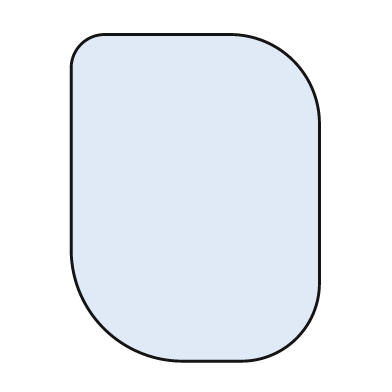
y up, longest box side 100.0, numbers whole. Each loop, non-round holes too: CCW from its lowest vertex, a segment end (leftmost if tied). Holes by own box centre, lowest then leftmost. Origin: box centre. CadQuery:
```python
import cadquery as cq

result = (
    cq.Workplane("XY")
    .moveTo(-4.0, -50.0)
    .lineTo(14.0, -50.0)
    .threePointArc((31.0, -43.0), (38.0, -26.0))
    .lineTo(38.0, 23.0)
    .threePointArc((30.0, 42.0), (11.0, 50.0))
    .lineTo(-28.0, 50.0)
    .threePointArc((-35.0, 47.0), (-38.0, 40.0))
    .lineTo(-38.0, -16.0)
    .threePointArc((-28.0, -40.0), (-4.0, -50.0))
    .close()
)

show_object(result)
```